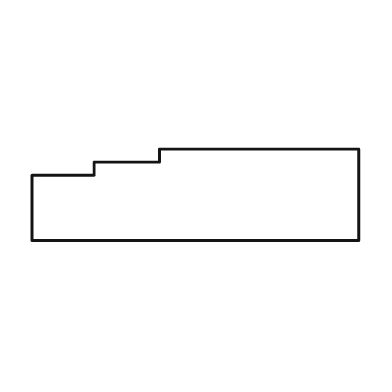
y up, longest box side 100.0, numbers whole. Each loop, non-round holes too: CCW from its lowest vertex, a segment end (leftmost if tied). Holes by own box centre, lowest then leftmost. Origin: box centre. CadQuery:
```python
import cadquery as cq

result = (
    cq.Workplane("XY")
    .moveTo(-50.0, -14.0)
    .lineTo(50.0, -14.0)
    .lineTo(50.0, 14.0)
    .lineTo(-11.0, 14.0)
    .lineTo(-11.0, 10.0)
    .lineTo(-31.0, 10.0)
    .lineTo(-31.0, 6.0)
    .lineTo(-50.0, 6.0)
    .close()
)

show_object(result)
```